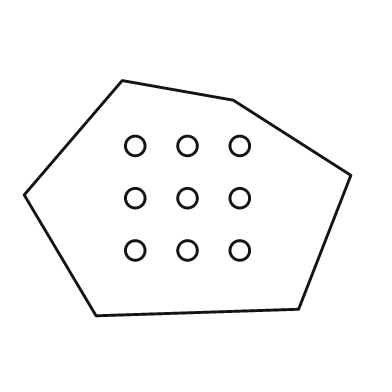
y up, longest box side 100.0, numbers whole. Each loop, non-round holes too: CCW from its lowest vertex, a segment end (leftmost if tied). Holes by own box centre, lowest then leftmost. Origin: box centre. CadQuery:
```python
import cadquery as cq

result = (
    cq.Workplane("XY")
    .moveTo(-28.0, -36.0)
    .lineTo(34.0, -34.0)
    .lineTo(50.0, 7.0)
    .lineTo(14.0, 30.0)
    .lineTo(-20.0, 36.0)
    .lineTo(-50.0, 1.0)
    .close()
    .moveTo(-16.0, -16.0)
    .circle(3.0)
    .moveTo(0.0, -16.0)
    .circle(3.0)
    .moveTo(16.0, -16.0)
    .circle(3.0)
    .moveTo(-16.0, 0.0)
    .circle(3.0)
    .moveTo(0.0, 0.0)
    .circle(3.0)
    .moveTo(16.0, 0.0)
    .circle(3.0)
    .moveTo(-16.0, 16.0)
    .circle(3.0)
    .moveTo(0.0, 16.0)
    .circle(3.0)
    .moveTo(16.0, 16.0)
    .circle(3.0)
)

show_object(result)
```